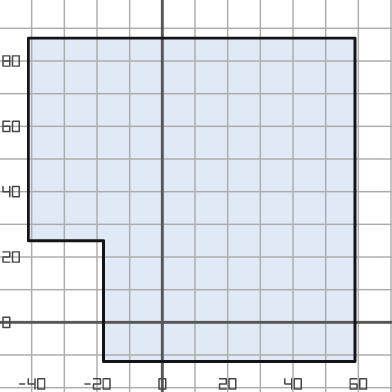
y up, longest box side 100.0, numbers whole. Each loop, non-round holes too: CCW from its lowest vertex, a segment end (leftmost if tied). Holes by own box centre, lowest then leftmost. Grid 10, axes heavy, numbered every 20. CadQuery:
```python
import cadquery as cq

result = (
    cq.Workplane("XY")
    .moveTo(-18.0, -12.0)
    .lineTo(59.0, -12.0)
    .lineTo(59.0, 87.0)
    .lineTo(-41.0, 87.0)
    .lineTo(-41.0, 25.0)
    .lineTo(-18.0, 25.0)
    .close()
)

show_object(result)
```